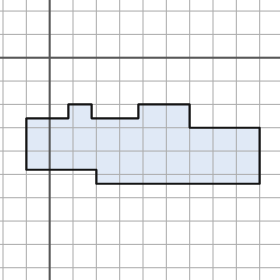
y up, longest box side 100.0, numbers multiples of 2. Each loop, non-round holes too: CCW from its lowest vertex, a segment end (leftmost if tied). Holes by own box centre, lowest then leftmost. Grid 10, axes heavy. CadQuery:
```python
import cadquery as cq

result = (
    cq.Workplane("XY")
    .moveTo(20.0, -54.0)
    .lineTo(90.0, -54.0)
    .lineTo(90.0, -30.0)
    .lineTo(60.0, -30.0)
    .lineTo(60.0, -20.0)
    .lineTo(38.0, -20.0)
    .lineTo(38.0, -26.0)
    .lineTo(18.0, -26.0)
    .lineTo(18.0, -20.0)
    .lineTo(8.0, -20.0)
    .lineTo(8.0, -26.0)
    .lineTo(-10.0, -26.0)
    .lineTo(-10.0, -48.0)
    .lineTo(20.0, -48.0)
    .close()
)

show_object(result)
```